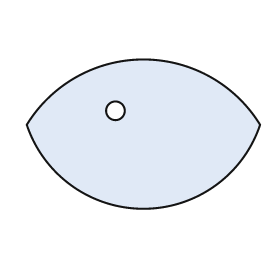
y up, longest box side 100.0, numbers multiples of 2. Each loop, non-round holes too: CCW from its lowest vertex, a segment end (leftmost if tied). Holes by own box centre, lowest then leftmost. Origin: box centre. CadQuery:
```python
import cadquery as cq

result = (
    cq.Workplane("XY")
    .moveTo(-50.0, 4.0)
    .threePointArc((0.0, -32.0), (50.0, 4.0))
    .threePointArc((0.0, 32.0), (-50.0, 4.0))
    .close()
    .moveTo(-12.0, 10.0)
    .circle(4.0)
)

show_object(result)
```